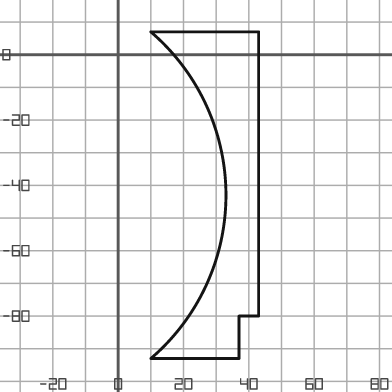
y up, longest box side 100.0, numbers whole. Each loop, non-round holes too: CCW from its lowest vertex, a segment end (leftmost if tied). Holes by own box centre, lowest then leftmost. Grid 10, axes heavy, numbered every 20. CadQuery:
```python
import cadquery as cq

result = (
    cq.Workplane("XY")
    .moveTo(10.0, -93.0)
    .lineTo(37.0, -93.0)
    .lineTo(37.0, -80.0)
    .lineTo(43.0, -80.0)
    .lineTo(43.0, 7.0)
    .lineTo(10.0, 7.0)
    .threePointArc((33.0, -43.0), (10.0, -93.0))
    .close()
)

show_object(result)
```